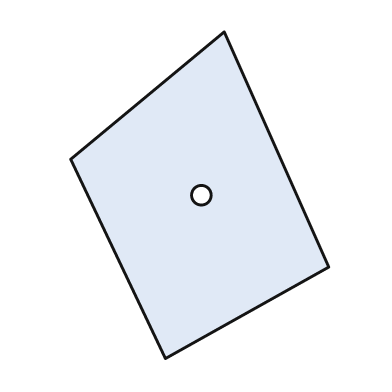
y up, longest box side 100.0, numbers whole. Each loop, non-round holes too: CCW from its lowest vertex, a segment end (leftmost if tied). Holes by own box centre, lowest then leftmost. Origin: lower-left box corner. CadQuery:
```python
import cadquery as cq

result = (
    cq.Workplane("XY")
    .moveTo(29.0, 0.0)
    .lineTo(79.0, 28.0)
    .lineTo(47.0, 100.0)
    .lineTo(0.0, 61.0)
    .close()
    .moveTo(40.0, 50.0)
    .circle(3.0)
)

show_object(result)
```